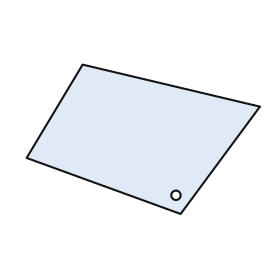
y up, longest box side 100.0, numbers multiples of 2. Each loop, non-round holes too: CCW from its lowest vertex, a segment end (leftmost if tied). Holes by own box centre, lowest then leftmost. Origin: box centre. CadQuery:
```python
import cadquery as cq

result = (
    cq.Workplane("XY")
    .moveTo(16.0, -32.0)
    .lineTo(50.0, 14.0)
    .lineTo(-26.0, 32.0)
    .lineTo(-50.0, -8.0)
    .close()
    .moveTo(14.0, -24.0)
    .circle(2.0)
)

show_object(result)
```